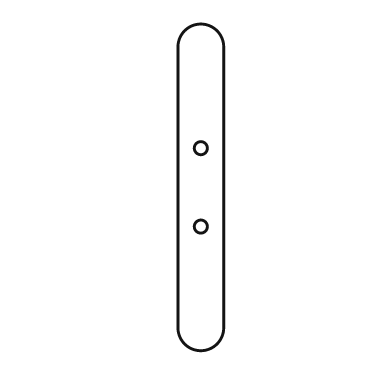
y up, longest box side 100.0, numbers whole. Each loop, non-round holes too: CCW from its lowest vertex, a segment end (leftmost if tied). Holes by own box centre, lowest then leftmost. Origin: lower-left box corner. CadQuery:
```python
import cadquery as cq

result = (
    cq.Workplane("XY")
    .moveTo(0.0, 7.0)
    .threePointArc((7.0, 0.0), (14.0, 7.0))
    .lineTo(14.0, 93.0)
    .threePointArc((7.0, 100.0), (0.0, 93.0))
    .close()
    .moveTo(7.0, 38.0)
    .circle(2.0)
    .moveTo(7.0, 62.0)
    .circle(2.0)
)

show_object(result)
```